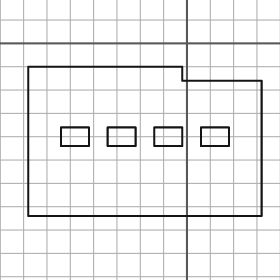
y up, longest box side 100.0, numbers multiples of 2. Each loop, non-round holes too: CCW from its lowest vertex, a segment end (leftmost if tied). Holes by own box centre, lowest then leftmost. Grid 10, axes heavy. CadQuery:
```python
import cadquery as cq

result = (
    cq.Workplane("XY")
    .moveTo(-68.0, -74.0)
    .lineTo(32.0, -74.0)
    .lineTo(32.0, -16.0)
    .lineTo(-2.0, -16.0)
    .lineTo(-2.0, -10.0)
    .lineTo(-68.0, -10.0)
    .close()
    .moveTo(-54.0, -44.0)
    .lineTo(-42.0, -44.0)
    .lineTo(-42.0, -36.0)
    .lineTo(-54.0, -36.0)
    .close()
    .moveTo(-34.0, -44.0)
    .lineTo(-22.0, -44.0)
    .lineTo(-22.0, -36.0)
    .lineTo(-34.0, -36.0)
    .close()
    .moveTo(-14.0, -44.0)
    .lineTo(-2.0, -44.0)
    .lineTo(-2.0, -36.0)
    .lineTo(-14.0, -36.0)
    .close()
    .moveTo(6.0, -44.0)
    .lineTo(18.0, -44.0)
    .lineTo(18.0, -36.0)
    .lineTo(6.0, -36.0)
    .close()
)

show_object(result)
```